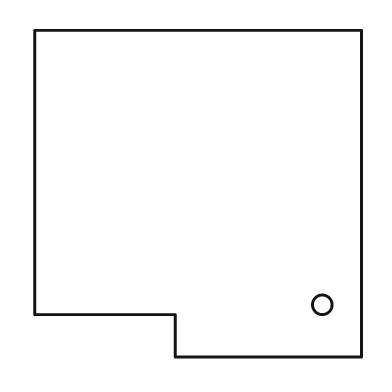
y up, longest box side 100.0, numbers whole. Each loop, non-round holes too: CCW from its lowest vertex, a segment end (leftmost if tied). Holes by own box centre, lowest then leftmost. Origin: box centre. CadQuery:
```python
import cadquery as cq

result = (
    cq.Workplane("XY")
    .moveTo(-7.0, -50.0)
    .lineTo(50.0, -50.0)
    .lineTo(50.0, 50.0)
    .lineTo(-50.0, 50.0)
    .lineTo(-50.0, -37.0)
    .lineTo(-7.0, -37.0)
    .close()
    .moveTo(38.0, -34.0)
    .circle(3.0)
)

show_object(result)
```